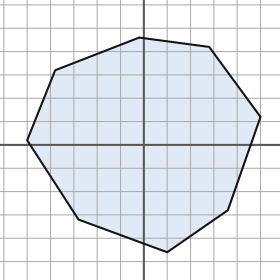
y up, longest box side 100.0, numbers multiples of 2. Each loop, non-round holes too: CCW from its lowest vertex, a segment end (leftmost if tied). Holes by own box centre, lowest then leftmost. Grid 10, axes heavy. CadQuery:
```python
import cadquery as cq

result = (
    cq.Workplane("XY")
    .moveTo(10.0, -46.0)
    .lineTo(36.0, -28.0)
    .lineTo(50.0, 12.0)
    .lineTo(28.0, 42.0)
    .lineTo(-2.0, 46.0)
    .lineTo(-38.0, 32.0)
    .lineTo(-50.0, 2.0)
    .lineTo(-28.0, -32.0)
    .close()
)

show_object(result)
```